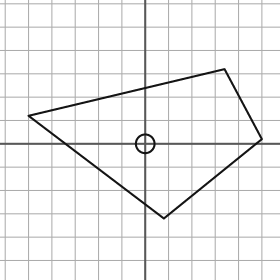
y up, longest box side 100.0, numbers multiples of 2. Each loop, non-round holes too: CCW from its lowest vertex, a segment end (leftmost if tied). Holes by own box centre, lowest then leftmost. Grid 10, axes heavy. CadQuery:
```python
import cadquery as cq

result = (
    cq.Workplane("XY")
    .moveTo(8.0, -32.0)
    .lineTo(50.0, 2.0)
    .lineTo(34.0, 32.0)
    .lineTo(-50.0, 12.0)
    .close()
    .moveTo(0.0, 0.0)
    .circle(4.0)
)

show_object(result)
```